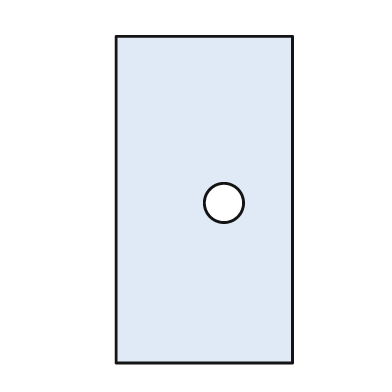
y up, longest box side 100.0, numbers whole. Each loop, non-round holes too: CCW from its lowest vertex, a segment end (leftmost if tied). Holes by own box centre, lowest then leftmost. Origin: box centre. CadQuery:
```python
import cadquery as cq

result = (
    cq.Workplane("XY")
    .moveTo(-27.0, -50.0)
    .lineTo(27.0, -50.0)
    .lineTo(27.0, 50.0)
    .lineTo(-27.0, 50.0)
    .close()
    .moveTo(6.0, -1.0)
    .circle(6.0)
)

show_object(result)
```